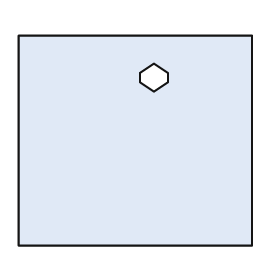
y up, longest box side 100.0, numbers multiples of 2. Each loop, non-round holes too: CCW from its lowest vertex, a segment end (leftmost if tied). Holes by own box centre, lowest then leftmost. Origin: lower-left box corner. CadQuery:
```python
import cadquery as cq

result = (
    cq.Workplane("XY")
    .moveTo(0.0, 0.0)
    .lineTo(100.0, 0.0)
    .lineTo(100.0, 90.0)
    .lineTo(0.0, 90.0)
    .close()
    .moveTo(58.0, 66.0)
    .lineTo(64.0, 70.0)
    .lineTo(64.0, 74.0)
    .lineTo(58.0, 78.0)
    .lineTo(52.0, 74.0)
    .lineTo(52.0, 70.0)
    .close()
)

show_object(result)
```